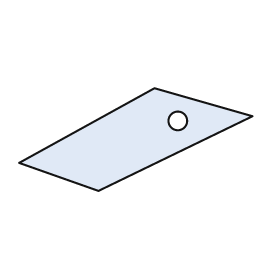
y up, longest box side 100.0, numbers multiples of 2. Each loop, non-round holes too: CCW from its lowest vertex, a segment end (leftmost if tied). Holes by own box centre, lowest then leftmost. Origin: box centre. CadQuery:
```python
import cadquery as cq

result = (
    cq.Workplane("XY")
    .moveTo(-16.0, -22.0)
    .lineTo(50.0, 10.0)
    .lineTo(8.0, 22.0)
    .lineTo(-50.0, -10.0)
    .close()
    .moveTo(18.0, 8.0)
    .circle(4.0)
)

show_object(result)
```